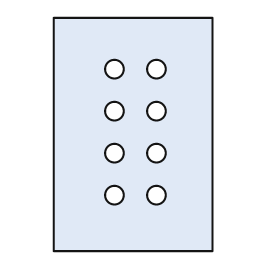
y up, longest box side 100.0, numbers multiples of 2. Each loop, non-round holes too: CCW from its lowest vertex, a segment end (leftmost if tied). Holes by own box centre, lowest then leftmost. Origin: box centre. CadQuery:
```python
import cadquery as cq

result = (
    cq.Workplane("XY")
    .moveTo(-34.0, -50.0)
    .lineTo(34.0, -50.0)
    .lineTo(34.0, 50.0)
    .lineTo(-34.0, 50.0)
    .close()
    .moveTo(-8.0, -26.0)
    .circle(4.0)
    .moveTo(10.0, -26.0)
    .circle(4.0)
    .moveTo(-8.0, -8.0)
    .circle(4.0)
    .moveTo(10.0, -8.0)
    .circle(4.0)
    .moveTo(-8.0, 10.0)
    .circle(4.0)
    .moveTo(10.0, 10.0)
    .circle(4.0)
    .moveTo(-8.0, 28.0)
    .circle(4.0)
    .moveTo(10.0, 28.0)
    .circle(4.0)
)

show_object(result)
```